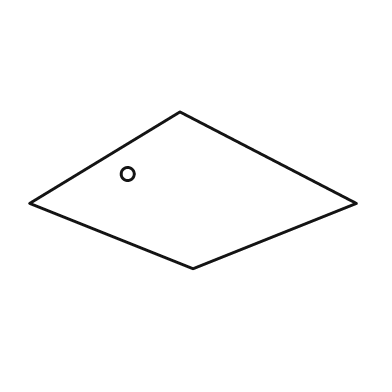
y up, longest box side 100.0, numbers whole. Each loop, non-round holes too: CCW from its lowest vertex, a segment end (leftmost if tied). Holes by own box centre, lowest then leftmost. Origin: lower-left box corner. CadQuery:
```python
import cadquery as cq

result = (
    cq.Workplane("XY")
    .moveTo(50.0, 0.0)
    .lineTo(100.0, 20.0)
    .lineTo(46.0, 48.0)
    .lineTo(0.0, 20.0)
    .close()
    .moveTo(30.0, 29.0)
    .circle(2.0)
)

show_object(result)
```